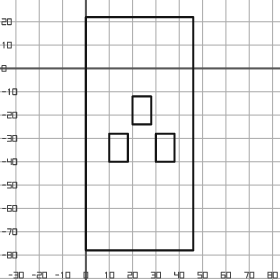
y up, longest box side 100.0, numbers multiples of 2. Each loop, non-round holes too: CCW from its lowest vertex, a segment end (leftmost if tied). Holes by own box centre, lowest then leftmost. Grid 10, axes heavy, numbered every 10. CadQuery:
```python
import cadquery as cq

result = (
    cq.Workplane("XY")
    .moveTo(0.0, -78.0)
    .lineTo(46.0, -78.0)
    .lineTo(46.0, 22.0)
    .lineTo(0.0, 22.0)
    .close()
    .moveTo(10.0, -40.0)
    .lineTo(18.0, -40.0)
    .lineTo(18.0, -28.0)
    .lineTo(10.0, -28.0)
    .close()
    .moveTo(30.0, -40.0)
    .lineTo(38.0, -40.0)
    .lineTo(38.0, -28.0)
    .lineTo(30.0, -28.0)
    .close()
    .moveTo(20.0, -24.0)
    .lineTo(28.0, -24.0)
    .lineTo(28.0, -12.0)
    .lineTo(20.0, -12.0)
    .close()
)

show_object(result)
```